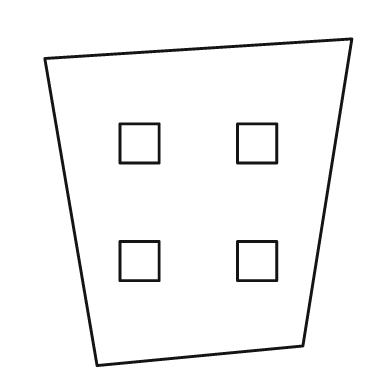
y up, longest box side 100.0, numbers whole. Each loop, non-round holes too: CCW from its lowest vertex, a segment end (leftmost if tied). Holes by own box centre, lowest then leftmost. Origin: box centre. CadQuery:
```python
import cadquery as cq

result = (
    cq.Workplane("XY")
    .moveTo(-31.0, -50.0)
    .lineTo(32.0, -44.0)
    .lineTo(47.0, 50.0)
    .lineTo(-47.0, 44.0)
    .close()
    .moveTo(-24.0, -24.0)
    .lineTo(-12.0, -24.0)
    .lineTo(-12.0, -12.0)
    .lineTo(-24.0, -12.0)
    .close()
    .moveTo(12.0, -24.0)
    .lineTo(24.0, -24.0)
    .lineTo(24.0, -12.0)
    .lineTo(12.0, -12.0)
    .close()
    .moveTo(-24.0, 12.0)
    .lineTo(-12.0, 12.0)
    .lineTo(-12.0, 24.0)
    .lineTo(-24.0, 24.0)
    .close()
    .moveTo(12.0, 12.0)
    .lineTo(24.0, 12.0)
    .lineTo(24.0, 24.0)
    .lineTo(12.0, 24.0)
    .close()
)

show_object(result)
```